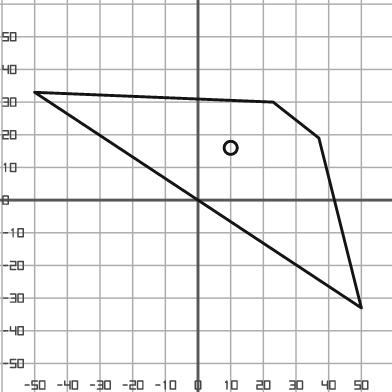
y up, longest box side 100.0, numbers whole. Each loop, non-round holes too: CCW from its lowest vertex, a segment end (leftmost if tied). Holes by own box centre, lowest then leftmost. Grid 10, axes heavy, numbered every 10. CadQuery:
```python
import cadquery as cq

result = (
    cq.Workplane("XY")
    .moveTo(50.0, -33.0)
    .lineTo(37.0, 19.0)
    .lineTo(23.0, 30.0)
    .lineTo(-50.0, 33.0)
    .close()
    .moveTo(10.0, 16.0)
    .circle(2.0)
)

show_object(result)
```